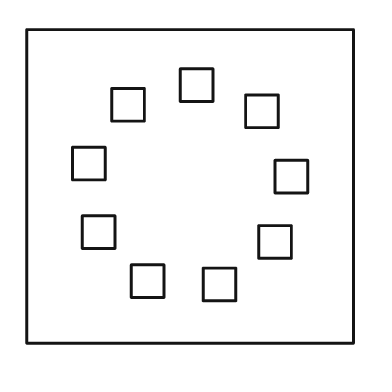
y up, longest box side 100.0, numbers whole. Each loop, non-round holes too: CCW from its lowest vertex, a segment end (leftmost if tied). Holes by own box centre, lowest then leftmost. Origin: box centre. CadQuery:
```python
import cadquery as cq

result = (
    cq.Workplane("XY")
    .moveTo(-50.0, -48.0)
    .lineTo(50.0, -48.0)
    .lineTo(50.0, 48.0)
    .lineTo(-50.0, 48.0)
    .close()
    .moveTo(4.0, -35.0)
    .lineTo(14.0, -35.0)
    .lineTo(14.0, -25.0)
    .lineTo(4.0, -25.0)
    .close()
    .moveTo(-18.0, -34.0)
    .lineTo(-8.0, -34.0)
    .lineTo(-8.0, -24.0)
    .lineTo(-18.0, -24.0)
    .close()
    .moveTo(21.0, -22.0)
    .lineTo(31.0, -22.0)
    .lineTo(31.0, -12.0)
    .lineTo(21.0, -12.0)
    .close()
    .moveTo(-33.0, -19.0)
    .lineTo(-23.0, -19.0)
    .lineTo(-23.0, -9.0)
    .lineTo(-33.0, -9.0)
    .close()
    .moveTo(26.0, -2.0)
    .lineTo(36.0, -2.0)
    .lineTo(36.0, 8.0)
    .lineTo(26.0, 8.0)
    .close()
    .moveTo(-36.0, 2.0)
    .lineTo(-26.0, 2.0)
    .lineTo(-26.0, 12.0)
    .lineTo(-36.0, 12.0)
    .close()
    .moveTo(17.0, 18.0)
    .lineTo(27.0, 18.0)
    .lineTo(27.0, 28.0)
    .lineTo(17.0, 28.0)
    .close()
    .moveTo(-24.0, 20.0)
    .lineTo(-14.0, 20.0)
    .lineTo(-14.0, 30.0)
    .lineTo(-24.0, 30.0)
    .close()
    .moveTo(-3.0, 26.0)
    .lineTo(7.0, 26.0)
    .lineTo(7.0, 36.0)
    .lineTo(-3.0, 36.0)
    .close()
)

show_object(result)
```